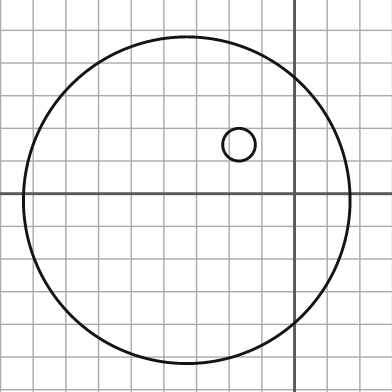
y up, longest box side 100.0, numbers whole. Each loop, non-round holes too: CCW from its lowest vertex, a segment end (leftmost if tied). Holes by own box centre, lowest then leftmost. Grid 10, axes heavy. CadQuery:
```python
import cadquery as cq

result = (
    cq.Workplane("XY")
    .moveTo(-33.0, -2.0)
    .circle(50.0)
    .moveTo(-17.0, 15.0)
    .circle(5.0)
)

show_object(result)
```